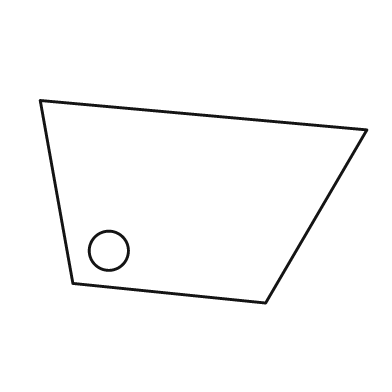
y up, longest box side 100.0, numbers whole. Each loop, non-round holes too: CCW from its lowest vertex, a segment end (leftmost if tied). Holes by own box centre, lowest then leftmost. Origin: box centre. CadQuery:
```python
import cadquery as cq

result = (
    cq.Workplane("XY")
    .moveTo(19.0, -31.0)
    .lineTo(50.0, 22.0)
    .lineTo(-50.0, 31.0)
    .lineTo(-40.0, -25.0)
    .close()
    .moveTo(-29.0, -15.0)
    .circle(6.0)
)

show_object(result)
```